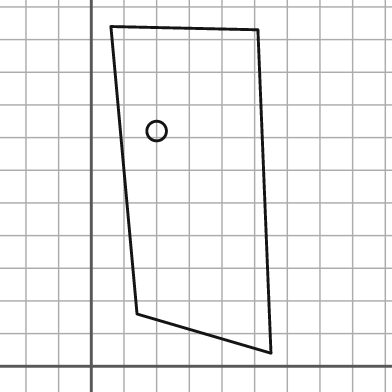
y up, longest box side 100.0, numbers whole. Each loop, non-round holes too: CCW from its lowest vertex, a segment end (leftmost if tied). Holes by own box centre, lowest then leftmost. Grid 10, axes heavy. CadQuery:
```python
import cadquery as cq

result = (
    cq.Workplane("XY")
    .moveTo(55.0, 4.0)
    .lineTo(51.0, 103.0)
    .lineTo(6.0, 104.0)
    .lineTo(14.0, 16.0)
    .close()
    .moveTo(20.0, 72.0)
    .circle(3.0)
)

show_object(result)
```